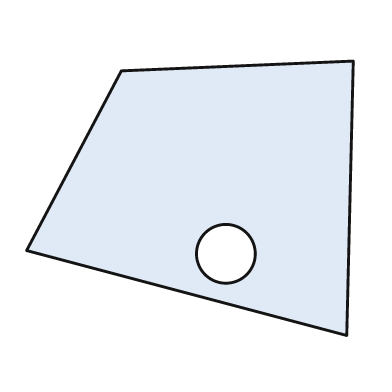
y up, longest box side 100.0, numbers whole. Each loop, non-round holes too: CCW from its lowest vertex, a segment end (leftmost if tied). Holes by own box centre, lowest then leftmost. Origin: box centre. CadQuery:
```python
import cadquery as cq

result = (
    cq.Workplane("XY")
    .moveTo(48.0, -42.0)
    .lineTo(50.0, 42.0)
    .lineTo(-21.0, 39.0)
    .lineTo(-50.0, -16.0)
    .close()
    .moveTo(11.0, -17.0)
    .circle(9.0)
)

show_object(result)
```